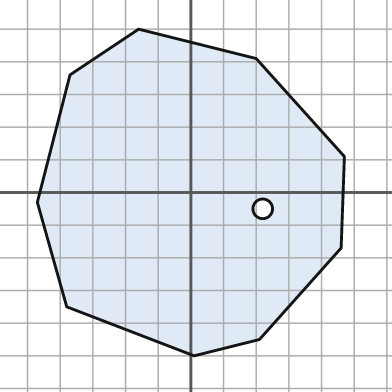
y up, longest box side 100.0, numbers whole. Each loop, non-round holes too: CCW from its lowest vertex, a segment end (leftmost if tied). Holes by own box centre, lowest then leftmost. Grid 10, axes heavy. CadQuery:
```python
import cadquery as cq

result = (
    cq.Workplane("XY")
    .moveTo(1.0, -50.0)
    .lineTo(21.0, -45.0)
    .lineTo(46.0, -17.0)
    .lineTo(47.0, 11.0)
    .lineTo(20.0, 41.0)
    .lineTo(-16.0, 50.0)
    .lineTo(-37.0, 36.0)
    .lineTo(-47.0, -3.0)
    .lineTo(-38.0, -35.0)
    .close()
    .moveTo(22.0, -5.0)
    .circle(3.0)
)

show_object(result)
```